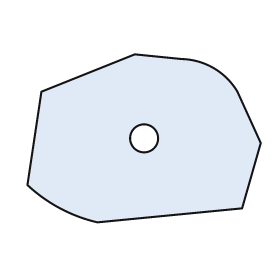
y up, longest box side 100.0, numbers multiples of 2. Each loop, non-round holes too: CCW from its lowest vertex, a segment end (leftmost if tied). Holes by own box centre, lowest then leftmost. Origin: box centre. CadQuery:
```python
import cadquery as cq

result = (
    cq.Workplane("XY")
    .moveTo(-20.0, -36.0)
    .lineTo(42.0, -30.0)
    .lineTo(50.0, -2.0)
    .lineTo(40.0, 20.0)
    .threePointArc((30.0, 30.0), (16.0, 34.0))
    .lineTo(-4.0, 36.0)
    .lineTo(-44.0, 20.0)
    .lineTo(-50.0, -20.0)
    .threePointArc((-36.0, -30.0), (-20.0, -36.0))
    .close()
    .moveTo(0.0, 0.0)
    .circle(6.0)
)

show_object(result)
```